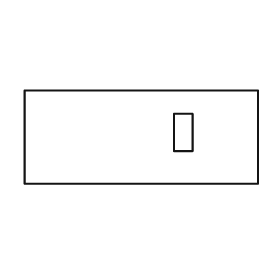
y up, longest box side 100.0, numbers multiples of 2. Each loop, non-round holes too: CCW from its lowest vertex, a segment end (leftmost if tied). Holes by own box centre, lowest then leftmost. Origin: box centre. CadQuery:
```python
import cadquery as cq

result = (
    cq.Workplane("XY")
    .moveTo(-50.0, -20.0)
    .lineTo(50.0, -20.0)
    .lineTo(50.0, 20.0)
    .lineTo(-50.0, 20.0)
    .close()
    .moveTo(14.0, -6.0)
    .lineTo(22.0, -6.0)
    .lineTo(22.0, 10.0)
    .lineTo(14.0, 10.0)
    .close()
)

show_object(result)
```